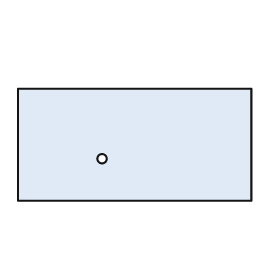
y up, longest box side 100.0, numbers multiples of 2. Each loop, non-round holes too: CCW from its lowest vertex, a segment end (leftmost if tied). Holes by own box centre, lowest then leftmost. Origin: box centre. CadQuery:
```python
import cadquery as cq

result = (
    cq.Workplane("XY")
    .moveTo(-50.0, -24.0)
    .lineTo(50.0, -24.0)
    .lineTo(50.0, 24.0)
    .lineTo(-50.0, 24.0)
    .close()
    .moveTo(-14.0, -6.0)
    .circle(2.0)
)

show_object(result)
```